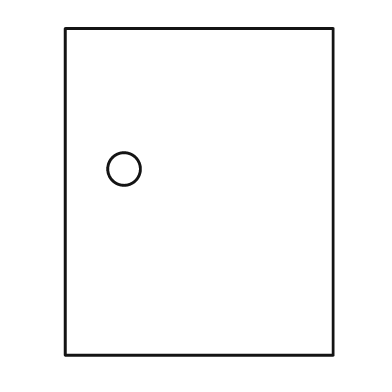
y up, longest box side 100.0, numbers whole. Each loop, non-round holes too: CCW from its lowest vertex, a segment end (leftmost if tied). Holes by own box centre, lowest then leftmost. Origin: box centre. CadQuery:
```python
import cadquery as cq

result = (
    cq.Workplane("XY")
    .moveTo(-41.0, -50.0)
    .lineTo(41.0, -50.0)
    .lineTo(41.0, 50.0)
    .lineTo(-41.0, 50.0)
    .close()
    .moveTo(-23.0, 7.0)
    .circle(5.0)
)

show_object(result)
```